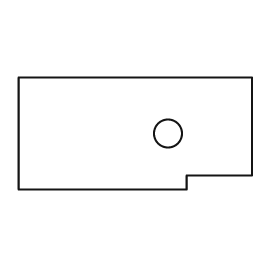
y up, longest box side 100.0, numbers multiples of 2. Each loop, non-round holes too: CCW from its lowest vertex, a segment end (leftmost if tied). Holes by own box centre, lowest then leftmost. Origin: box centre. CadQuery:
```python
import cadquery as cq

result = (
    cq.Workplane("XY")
    .moveTo(-50.0, -24.0)
    .lineTo(22.0, -24.0)
    .lineTo(22.0, -18.0)
    .lineTo(50.0, -18.0)
    .lineTo(50.0, 24.0)
    .lineTo(-50.0, 24.0)
    .close()
    .moveTo(14.0, 0.0)
    .circle(6.0)
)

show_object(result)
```